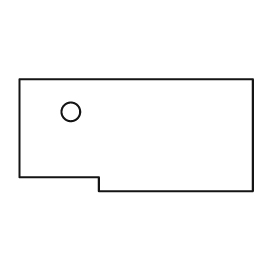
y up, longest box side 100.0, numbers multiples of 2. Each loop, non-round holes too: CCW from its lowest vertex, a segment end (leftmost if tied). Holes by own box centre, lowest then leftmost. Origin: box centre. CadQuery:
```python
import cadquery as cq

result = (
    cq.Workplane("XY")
    .moveTo(-16.0, -24.0)
    .lineTo(50.0, -24.0)
    .lineTo(50.0, 24.0)
    .lineTo(-50.0, 24.0)
    .lineTo(-50.0, -18.0)
    .lineTo(-16.0, -18.0)
    .close()
    .moveTo(-28.0, 10.0)
    .circle(4.0)
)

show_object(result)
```